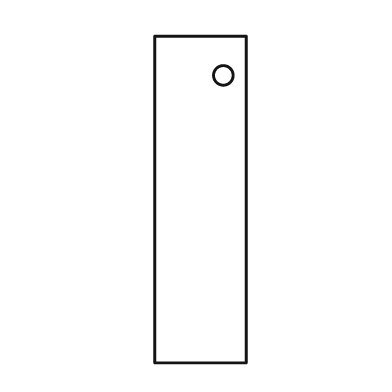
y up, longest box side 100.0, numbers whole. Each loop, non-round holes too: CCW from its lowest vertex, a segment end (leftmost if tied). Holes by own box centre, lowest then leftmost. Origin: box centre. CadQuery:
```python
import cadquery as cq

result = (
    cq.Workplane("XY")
    .moveTo(-14.0, -50.0)
    .lineTo(14.0, -50.0)
    .lineTo(14.0, 50.0)
    .lineTo(-14.0, 50.0)
    .close()
    .moveTo(7.0, 38.0)
    .circle(3.0)
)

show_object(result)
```